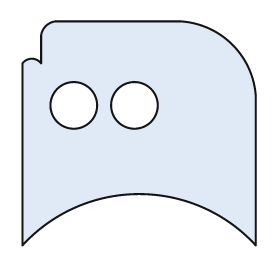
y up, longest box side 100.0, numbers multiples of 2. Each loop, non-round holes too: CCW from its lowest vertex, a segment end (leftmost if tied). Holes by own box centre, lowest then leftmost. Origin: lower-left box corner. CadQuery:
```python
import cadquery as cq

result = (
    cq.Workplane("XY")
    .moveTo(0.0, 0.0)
    .threePointArc((50.0, 22.0), (100.0, 0.0))
    .lineTo(100.0, 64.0)
    .threePointArc((90.0, 86.0), (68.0, 96.0))
    .lineTo(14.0, 96.0)
    .threePointArc((10.0, 94.0), (8.0, 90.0))
    .lineTo(8.0, 78.0)
    .threePointArc((4.0, 80.0), (0.0, 78.0))
    .close()
    .moveTo(22.0, 60.0)
    .circle(10.0)
    .moveTo(48.0, 60.0)
    .circle(10.0)
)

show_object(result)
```